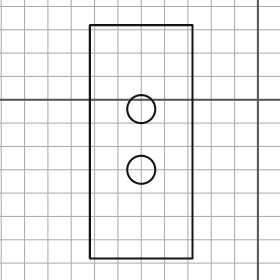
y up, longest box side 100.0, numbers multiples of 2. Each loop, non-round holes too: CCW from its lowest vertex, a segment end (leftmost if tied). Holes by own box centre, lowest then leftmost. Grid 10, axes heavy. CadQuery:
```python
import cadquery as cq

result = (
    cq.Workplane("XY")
    .moveTo(-72.0, -68.0)
    .lineTo(-28.0, -68.0)
    .lineTo(-28.0, 32.0)
    .lineTo(-72.0, 32.0)
    .close()
    .moveTo(-50.0, -30.0)
    .circle(6.0)
    .moveTo(-50.0, -4.0)
    .circle(6.0)
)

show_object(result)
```